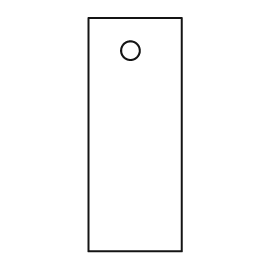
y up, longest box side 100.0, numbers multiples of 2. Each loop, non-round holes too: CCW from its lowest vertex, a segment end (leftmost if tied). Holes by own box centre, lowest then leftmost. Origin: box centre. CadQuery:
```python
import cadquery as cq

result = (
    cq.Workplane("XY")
    .moveTo(-20.0, -50.0)
    .lineTo(20.0, -50.0)
    .lineTo(20.0, 50.0)
    .lineTo(-20.0, 50.0)
    .close()
    .moveTo(-2.0, 36.0)
    .circle(4.0)
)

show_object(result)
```